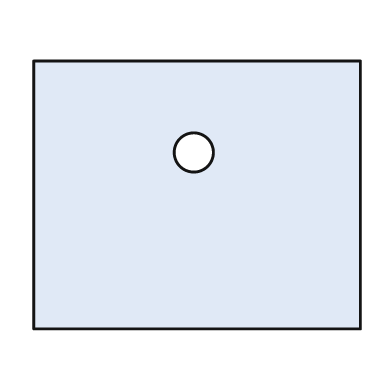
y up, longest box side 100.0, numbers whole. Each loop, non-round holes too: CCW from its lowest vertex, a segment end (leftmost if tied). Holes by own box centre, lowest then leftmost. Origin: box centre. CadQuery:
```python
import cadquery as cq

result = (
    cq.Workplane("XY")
    .moveTo(-50.0, -41.0)
    .lineTo(50.0, -41.0)
    .lineTo(50.0, 41.0)
    .lineTo(-50.0, 41.0)
    .close()
    .moveTo(-1.0, 13.0)
    .circle(6.0)
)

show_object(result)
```